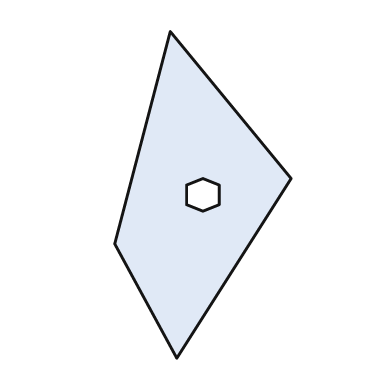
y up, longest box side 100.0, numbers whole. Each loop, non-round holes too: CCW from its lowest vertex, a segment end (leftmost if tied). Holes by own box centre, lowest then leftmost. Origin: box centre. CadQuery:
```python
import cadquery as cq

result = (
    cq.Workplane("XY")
    .moveTo(-8.0, -50.0)
    .lineTo(27.0, 5.0)
    .lineTo(-10.0, 50.0)
    .lineTo(-27.0, -15.0)
    .close()
    .moveTo(0.0, -5.0)
    .lineTo(5.0, -3.0)
    .lineTo(5.0, 3.0)
    .lineTo(0.0, 5.0)
    .lineTo(-5.0, 3.0)
    .lineTo(-5.0, -3.0)
    .close()
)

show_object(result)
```